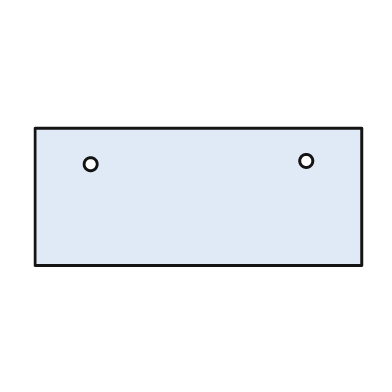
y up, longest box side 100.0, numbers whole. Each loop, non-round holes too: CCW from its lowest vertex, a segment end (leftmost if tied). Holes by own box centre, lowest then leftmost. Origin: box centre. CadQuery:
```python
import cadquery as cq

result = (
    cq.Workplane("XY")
    .moveTo(-50.0, -21.0)
    .lineTo(50.0, -21.0)
    .lineTo(50.0, 21.0)
    .lineTo(-50.0, 21.0)
    .close()
    .moveTo(-33.0, 10.0)
    .circle(2.0)
    .moveTo(33.0, 11.0)
    .circle(2.0)
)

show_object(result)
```